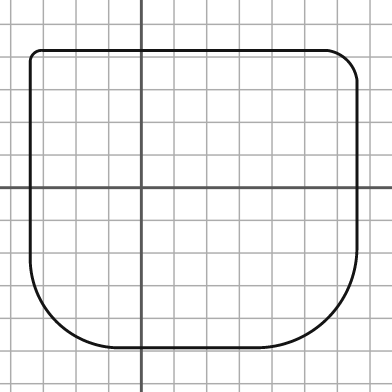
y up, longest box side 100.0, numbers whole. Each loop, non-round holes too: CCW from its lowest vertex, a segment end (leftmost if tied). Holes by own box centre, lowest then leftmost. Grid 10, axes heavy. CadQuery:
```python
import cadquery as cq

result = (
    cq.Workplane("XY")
    .moveTo(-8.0, -49.0)
    .lineTo(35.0, -49.0)
    .threePointArc((57.0, -40.0), (66.0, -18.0))
    .lineTo(66.0, 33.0)
    .threePointArc((63.0, 39.0), (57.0, 42.0))
    .lineTo(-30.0, 42.0)
    .threePointArc((-33.0, 41.0), (-34.0, 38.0))
    .lineTo(-34.0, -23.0)
    .threePointArc((-26.0, -41.0), (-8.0, -49.0))
    .close()
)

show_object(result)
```